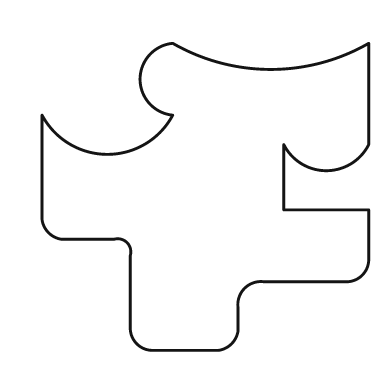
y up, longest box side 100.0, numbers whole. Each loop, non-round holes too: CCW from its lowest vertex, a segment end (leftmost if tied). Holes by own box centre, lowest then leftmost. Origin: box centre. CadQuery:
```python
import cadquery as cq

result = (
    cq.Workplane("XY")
    .moveTo(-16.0, -47.0)
    .lineTo(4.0, -47.0)
    .threePointArc((8.0, -45.0), (10.0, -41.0))
    .lineTo(10.0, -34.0)
    .threePointArc((12.0, -28.0), (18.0, -26.0))
    .lineTo(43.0, -26.0)
    .threePointArc((48.0, -24.0), (50.0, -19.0))
    .lineTo(50.0, -4.0)
    .lineTo(24.0, -4.0)
    .lineTo(24.0, 16.0)
    .threePointArc((37.0, 8.0), (50.0, 16.0))
    .lineTo(50.0, 47.0)
    .threePointArc((20.0, 39.0), (-10.0, 47.0))
    .threePointArc((-20.0, 36.0), (-10.0, 25.0))
    .threePointArc((-30.0, 13.0), (-50.0, 25.0))
    .lineTo(-50.0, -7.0)
    .threePointArc((-48.0, -11.0), (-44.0, -13.0))
    .lineTo(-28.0, -13.0)
    .threePointArc((-24.0, -14.0), (-23.0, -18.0))
    .lineTo(-23.0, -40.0)
    .threePointArc((-21.0, -45.0), (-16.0, -47.0))
    .close()
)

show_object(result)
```